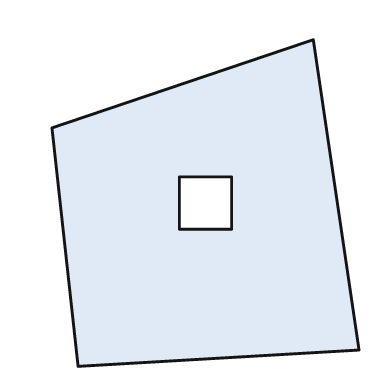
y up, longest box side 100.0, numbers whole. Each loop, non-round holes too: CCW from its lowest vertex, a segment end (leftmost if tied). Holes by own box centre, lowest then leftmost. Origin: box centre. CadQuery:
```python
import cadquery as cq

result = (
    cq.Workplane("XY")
    .moveTo(-39.0, -50.0)
    .lineTo(47.0, -45.0)
    .lineTo(33.0, 50.0)
    .lineTo(-47.0, 23.0)
    .close()
    .moveTo(-8.0, -8.0)
    .lineTo(8.0, -8.0)
    .lineTo(8.0, 8.0)
    .lineTo(-8.0, 8.0)
    .close()
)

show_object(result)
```